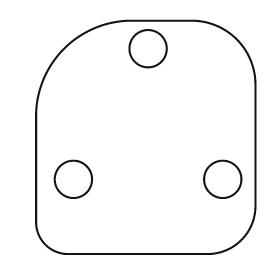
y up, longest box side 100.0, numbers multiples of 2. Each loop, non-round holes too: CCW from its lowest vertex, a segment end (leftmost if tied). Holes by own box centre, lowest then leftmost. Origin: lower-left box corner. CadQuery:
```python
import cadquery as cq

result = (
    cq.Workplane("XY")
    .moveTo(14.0, 0.0)
    .lineTo(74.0, 0.0)
    .threePointArc((88.0, 6.0), (94.0, 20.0))
    .lineTo(94.0, 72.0)
    .threePointArc((86.0, 92.0), (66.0, 100.0))
    .lineTo(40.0, 100.0)
    .threePointArc((12.0, 88.0), (0.0, 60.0))
    .lineTo(0.0, 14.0)
    .threePointArc((4.0, 4.0), (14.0, 0.0))
    .close()
    .moveTo(16.0, 32.0)
    .circle(8.0)
    .moveTo(80.0, 32.0)
    .circle(8.0)
    .moveTo(48.0, 88.0)
    .circle(8.0)
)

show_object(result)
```